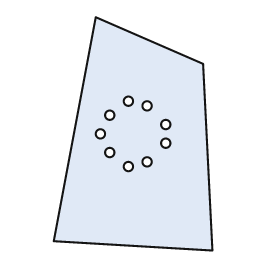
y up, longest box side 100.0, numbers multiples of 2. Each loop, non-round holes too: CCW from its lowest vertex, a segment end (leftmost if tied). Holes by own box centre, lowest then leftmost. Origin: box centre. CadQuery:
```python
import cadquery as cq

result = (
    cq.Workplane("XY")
    .moveTo(34.0, -50.0)
    .lineTo(30.0, 30.0)
    .lineTo(-16.0, 50.0)
    .lineTo(-34.0, -46.0)
    .close()
    .moveTo(-2.0, -14.0)
    .circle(2.0)
    .moveTo(6.0, -12.0)
    .circle(2.0)
    .moveTo(-10.0, -8.0)
    .circle(2.0)
    .moveTo(14.0, -4.0)
    .circle(2.0)
    .moveTo(-14.0, 0.0)
    .circle(2.0)
    .moveTo(14.0, 4.0)
    .circle(2.0)
    .moveTo(-10.0, 8.0)
    .circle(2.0)
    .moveTo(6.0, 12.0)
    .circle(2.0)
    .moveTo(-2.0, 14.0)
    .circle(2.0)
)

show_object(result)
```